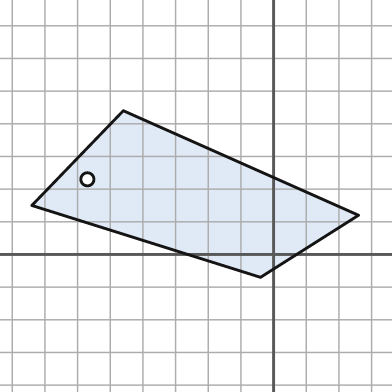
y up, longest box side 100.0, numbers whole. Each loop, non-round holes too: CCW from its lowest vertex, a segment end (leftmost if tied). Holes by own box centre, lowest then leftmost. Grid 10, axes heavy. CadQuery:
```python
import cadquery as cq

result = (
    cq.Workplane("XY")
    .moveTo(-4.0, -7.0)
    .lineTo(26.0, 12.0)
    .lineTo(-46.0, 44.0)
    .lineTo(-74.0, 15.0)
    .close()
    .moveTo(-57.0, 23.0)
    .circle(2.0)
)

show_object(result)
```